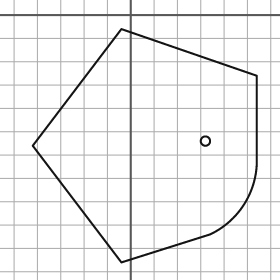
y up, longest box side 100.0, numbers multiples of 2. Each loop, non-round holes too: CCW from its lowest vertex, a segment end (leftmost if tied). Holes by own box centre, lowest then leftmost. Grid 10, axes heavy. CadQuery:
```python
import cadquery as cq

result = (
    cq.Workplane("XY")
    .moveTo(-4.0, -106.0)
    .lineTo(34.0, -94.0)
    .threePointArc((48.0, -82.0), (54.0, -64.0))
    .lineTo(54.0, -26.0)
    .lineTo(-4.0, -6.0)
    .lineTo(-42.0, -56.0)
    .close()
    .moveTo(32.0, -54.0)
    .circle(2.0)
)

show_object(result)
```